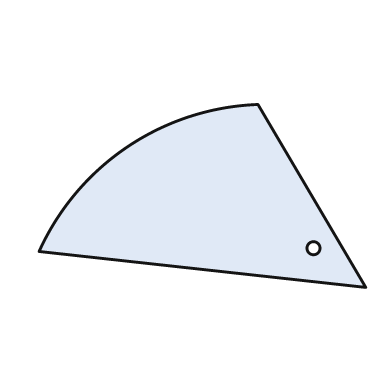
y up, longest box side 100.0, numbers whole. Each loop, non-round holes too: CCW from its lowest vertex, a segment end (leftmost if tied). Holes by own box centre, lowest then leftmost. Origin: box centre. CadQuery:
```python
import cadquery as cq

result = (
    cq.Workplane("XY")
    .moveTo(50.0, -28.0)
    .lineTo(17.0, 28.0)
    .threePointArc((-23.0, 15.0), (-50.0, -17.0))
    .close()
    .moveTo(34.0, -16.0)
    .circle(2.0)
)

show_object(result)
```